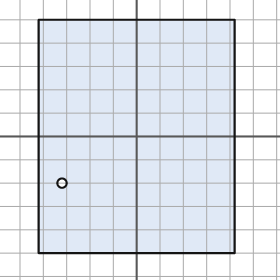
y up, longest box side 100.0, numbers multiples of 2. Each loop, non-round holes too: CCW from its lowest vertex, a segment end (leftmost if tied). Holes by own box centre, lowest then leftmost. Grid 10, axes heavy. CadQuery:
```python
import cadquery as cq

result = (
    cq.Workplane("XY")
    .moveTo(-42.0, -50.0)
    .lineTo(42.0, -50.0)
    .lineTo(42.0, 50.0)
    .lineTo(-42.0, 50.0)
    .close()
    .moveTo(-32.0, -20.0)
    .circle(2.0)
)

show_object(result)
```